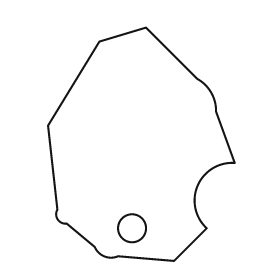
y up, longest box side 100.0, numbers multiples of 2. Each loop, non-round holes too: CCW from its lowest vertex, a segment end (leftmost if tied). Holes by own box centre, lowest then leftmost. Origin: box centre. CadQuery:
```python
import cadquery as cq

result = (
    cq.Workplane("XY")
    .moveTo(14.0, -50.0)
    .lineTo(28.0, -36.0)
    .threePointArc((24.0, -18.0), (40.0, -8.0))
    .lineTo(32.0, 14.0)
    .threePointArc((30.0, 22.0), (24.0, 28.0))
    .lineTo(2.0, 50.0)
    .lineTo(-18.0, 44.0)
    .lineTo(-40.0, 8.0)
    .lineTo(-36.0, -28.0)
    .threePointArc((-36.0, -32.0), (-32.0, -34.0))
    .lineTo(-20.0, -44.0)
    .threePointArc((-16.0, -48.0), (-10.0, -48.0))
    .close()
    .moveTo(-4.0, -36.0)
    .circle(6.0)
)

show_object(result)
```